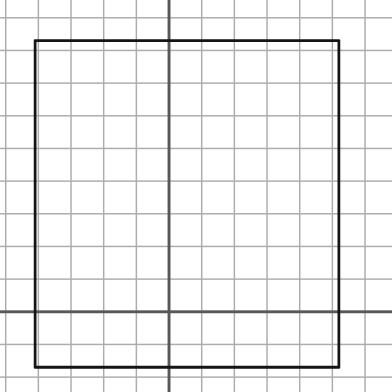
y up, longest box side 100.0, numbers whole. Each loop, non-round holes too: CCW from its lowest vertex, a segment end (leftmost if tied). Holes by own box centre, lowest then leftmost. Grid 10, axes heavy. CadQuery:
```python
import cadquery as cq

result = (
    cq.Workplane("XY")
    .moveTo(-41.0, -17.0)
    .lineTo(52.0, -17.0)
    .lineTo(52.0, 83.0)
    .lineTo(-41.0, 83.0)
    .close()
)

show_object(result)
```